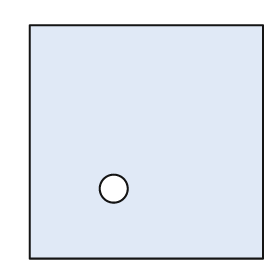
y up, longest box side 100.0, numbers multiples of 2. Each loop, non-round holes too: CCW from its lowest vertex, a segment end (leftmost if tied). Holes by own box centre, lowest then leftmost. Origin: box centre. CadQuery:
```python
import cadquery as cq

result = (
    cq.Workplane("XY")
    .moveTo(-50.0, -50.0)
    .lineTo(50.0, -50.0)
    .lineTo(50.0, 50.0)
    .lineTo(-50.0, 50.0)
    .close()
    .moveTo(-14.0, -20.0)
    .circle(6.0)
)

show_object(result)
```